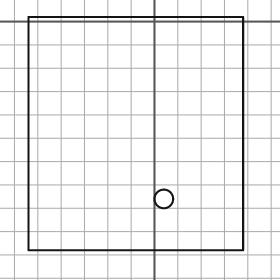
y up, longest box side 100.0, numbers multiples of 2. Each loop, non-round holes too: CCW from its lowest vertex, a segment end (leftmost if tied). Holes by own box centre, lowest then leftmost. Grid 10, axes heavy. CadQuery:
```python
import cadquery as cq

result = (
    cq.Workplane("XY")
    .moveTo(-54.0, -98.0)
    .lineTo(38.0, -98.0)
    .lineTo(38.0, 2.0)
    .lineTo(-54.0, 2.0)
    .close()
    .moveTo(4.0, -76.0)
    .circle(4.0)
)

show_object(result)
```